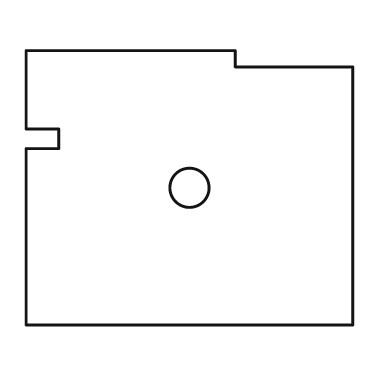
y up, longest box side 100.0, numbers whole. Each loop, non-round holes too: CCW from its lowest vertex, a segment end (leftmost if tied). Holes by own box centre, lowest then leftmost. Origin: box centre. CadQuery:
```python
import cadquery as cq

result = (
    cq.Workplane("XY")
    .moveTo(-50.0, -42.0)
    .lineTo(50.0, -42.0)
    .lineTo(50.0, 37.0)
    .lineTo(14.0, 37.0)
    .lineTo(14.0, 42.0)
    .lineTo(-50.0, 42.0)
    .lineTo(-50.0, 18.0)
    .lineTo(-40.0, 18.0)
    .lineTo(-40.0, 12.0)
    .lineTo(-50.0, 12.0)
    .close()
    .moveTo(0.0, 0.0)
    .circle(6.0)
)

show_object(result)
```